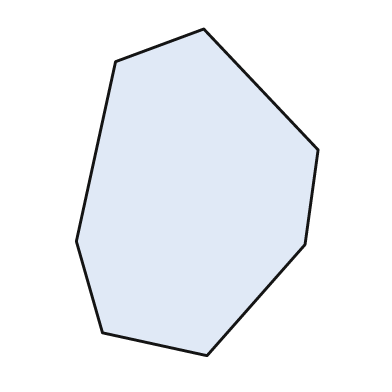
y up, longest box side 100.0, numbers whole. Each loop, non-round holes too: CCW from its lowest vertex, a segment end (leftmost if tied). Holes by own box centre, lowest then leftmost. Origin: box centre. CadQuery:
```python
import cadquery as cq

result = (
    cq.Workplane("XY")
    .moveTo(3.0, -50.0)
    .lineTo(33.0, -16.0)
    .lineTo(37.0, 13.0)
    .lineTo(2.0, 50.0)
    .lineTo(-25.0, 40.0)
    .lineTo(-37.0, -15.0)
    .lineTo(-29.0, -43.0)
    .close()
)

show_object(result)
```